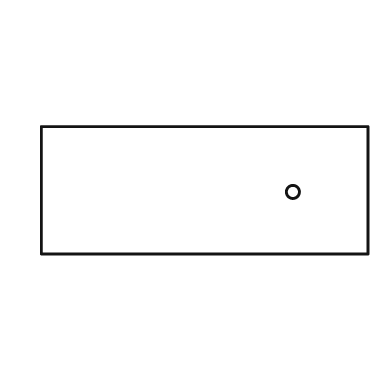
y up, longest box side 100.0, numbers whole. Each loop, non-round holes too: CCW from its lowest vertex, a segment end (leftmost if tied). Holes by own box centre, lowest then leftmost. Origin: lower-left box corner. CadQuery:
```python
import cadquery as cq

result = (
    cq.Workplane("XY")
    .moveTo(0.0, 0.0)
    .lineTo(100.0, 0.0)
    .lineTo(100.0, 39.0)
    .lineTo(0.0, 39.0)
    .close()
    .moveTo(77.0, 19.0)
    .circle(2.0)
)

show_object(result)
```